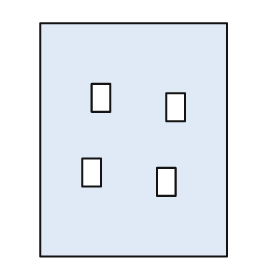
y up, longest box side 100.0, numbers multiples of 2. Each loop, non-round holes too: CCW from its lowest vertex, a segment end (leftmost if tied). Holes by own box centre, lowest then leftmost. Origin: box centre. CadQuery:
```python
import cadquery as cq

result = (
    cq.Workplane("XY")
    .moveTo(-40.0, -50.0)
    .lineTo(40.0, -50.0)
    .lineTo(40.0, 50.0)
    .lineTo(-40.0, 50.0)
    .close()
    .moveTo(10.0, -24.0)
    .lineTo(18.0, -24.0)
    .lineTo(18.0, -12.0)
    .lineTo(10.0, -12.0)
    .close()
    .moveTo(-22.0, -20.0)
    .lineTo(-14.0, -20.0)
    .lineTo(-14.0, -8.0)
    .lineTo(-22.0, -8.0)
    .close()
    .moveTo(14.0, 8.0)
    .lineTo(22.0, 8.0)
    .lineTo(22.0, 20.0)
    .lineTo(14.0, 20.0)
    .close()
    .moveTo(-18.0, 12.0)
    .lineTo(-10.0, 12.0)
    .lineTo(-10.0, 24.0)
    .lineTo(-18.0, 24.0)
    .close()
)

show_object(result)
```